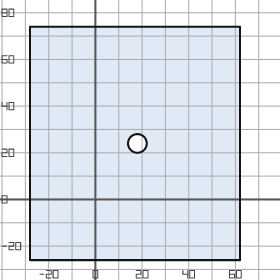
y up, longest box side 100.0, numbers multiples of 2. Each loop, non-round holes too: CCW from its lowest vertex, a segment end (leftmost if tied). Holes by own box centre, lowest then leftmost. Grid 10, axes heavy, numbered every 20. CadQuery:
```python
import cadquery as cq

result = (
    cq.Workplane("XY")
    .moveTo(-28.0, -26.0)
    .lineTo(62.0, -26.0)
    .lineTo(62.0, 74.0)
    .lineTo(-28.0, 74.0)
    .close()
    .moveTo(18.0, 24.0)
    .circle(4.0)
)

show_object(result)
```